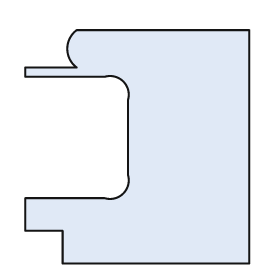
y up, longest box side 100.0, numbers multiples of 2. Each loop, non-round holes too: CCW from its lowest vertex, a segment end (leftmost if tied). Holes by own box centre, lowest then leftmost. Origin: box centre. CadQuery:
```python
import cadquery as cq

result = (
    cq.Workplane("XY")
    .moveTo(-32.0, -50.0)
    .lineTo(48.0, -50.0)
    .lineTo(48.0, 50.0)
    .lineTo(-26.0, 50.0)
    .threePointArc((-30.0, 42.0), (-26.0, 34.0))
    .lineTo(-48.0, 34.0)
    .lineTo(-48.0, 30.0)
    .lineTo(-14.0, 30.0)
    .threePointArc((-6.0, 28.0), (-4.0, 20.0))
    .lineTo(-4.0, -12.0)
    .threePointArc((-6.0, -20.0), (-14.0, -22.0))
    .lineTo(-48.0, -22.0)
    .lineTo(-48.0, -36.0)
    .lineTo(-32.0, -36.0)
    .close()
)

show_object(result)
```